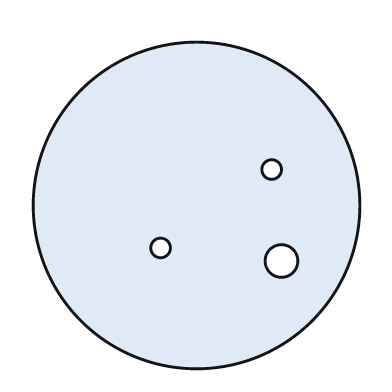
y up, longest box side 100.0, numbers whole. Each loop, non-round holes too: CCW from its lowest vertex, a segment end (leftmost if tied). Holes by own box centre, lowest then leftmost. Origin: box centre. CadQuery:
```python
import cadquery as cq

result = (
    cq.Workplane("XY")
    .moveTo(0.0, 0.0)
    .circle(50.0)
    .moveTo(26.0, -17.0)
    .circle(5.0)
    .moveTo(-11.0, -13.0)
    .circle(3.0)
    .moveTo(23.0, 11.0)
    .circle(3.0)
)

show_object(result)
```